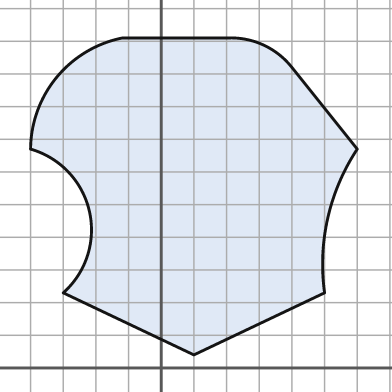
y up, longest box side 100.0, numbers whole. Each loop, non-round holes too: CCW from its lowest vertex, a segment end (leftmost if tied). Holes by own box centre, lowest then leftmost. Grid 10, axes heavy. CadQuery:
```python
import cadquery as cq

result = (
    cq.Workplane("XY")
    .moveTo(10.0, 4.0)
    .lineTo(50.0, 23.0)
    .threePointArc((51.0, 46.0), (60.0, 67.0))
    .lineTo(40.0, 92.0)
    .threePointArc((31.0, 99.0), (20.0, 101.0))
    .lineTo(-12.0, 101.0)
    .threePointArc((-32.0, 89.0), (-40.0, 67.0))
    .threePointArc((-22.0, 48.0), (-30.0, 23.0))
    .close()
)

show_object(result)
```